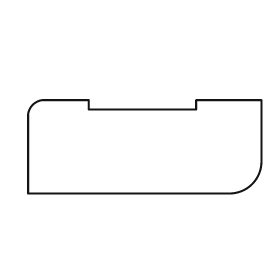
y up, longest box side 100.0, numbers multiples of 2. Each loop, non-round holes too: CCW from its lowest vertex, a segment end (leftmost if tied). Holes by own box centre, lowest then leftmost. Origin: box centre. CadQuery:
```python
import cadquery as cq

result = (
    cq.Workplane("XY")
    .moveTo(-50.0, -20.0)
    .lineTo(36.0, -20.0)
    .threePointArc((46.0, -16.0), (50.0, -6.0))
    .lineTo(50.0, 20.0)
    .lineTo(22.0, 20.0)
    .lineTo(22.0, 16.0)
    .lineTo(-24.0, 16.0)
    .lineTo(-24.0, 20.0)
    .lineTo(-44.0, 20.0)
    .threePointArc((-48.0, 18.0), (-50.0, 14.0))
    .close()
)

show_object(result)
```